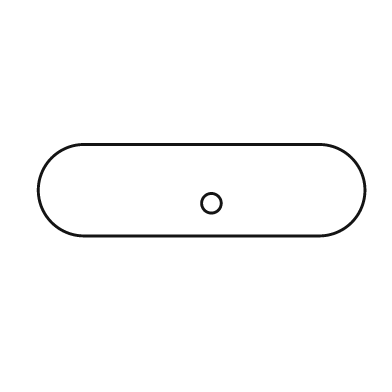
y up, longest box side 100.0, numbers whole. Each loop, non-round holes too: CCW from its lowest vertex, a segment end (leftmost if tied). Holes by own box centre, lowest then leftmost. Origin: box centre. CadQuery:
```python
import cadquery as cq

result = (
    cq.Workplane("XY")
    .moveTo(-36.0, -14.0)
    .lineTo(36.0, -14.0)
    .threePointArc((50.0, 0.0), (36.0, 14.0))
    .lineTo(-36.0, 14.0)
    .threePointArc((-50.0, 0.0), (-36.0, -14.0))
    .close()
    .moveTo(3.0, -4.0)
    .circle(3.0)
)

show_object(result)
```